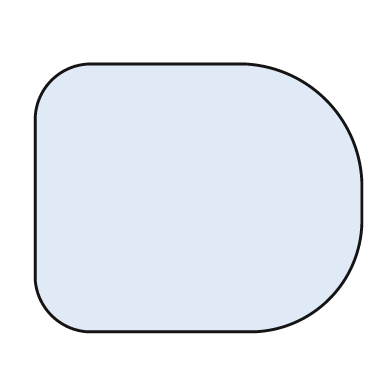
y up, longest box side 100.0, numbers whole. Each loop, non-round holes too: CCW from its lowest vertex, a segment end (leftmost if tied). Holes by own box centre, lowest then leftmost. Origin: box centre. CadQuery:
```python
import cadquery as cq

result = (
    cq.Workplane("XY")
    .moveTo(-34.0, -41.0)
    .lineTo(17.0, -41.0)
    .threePointArc((40.0, -31.0), (50.0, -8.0))
    .lineTo(50.0, 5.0)
    .threePointArc((39.0, 30.0), (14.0, 41.0))
    .lineTo(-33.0, 41.0)
    .threePointArc((-45.0, 36.0), (-50.0, 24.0))
    .lineTo(-50.0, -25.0)
    .threePointArc((-45.0, -36.0), (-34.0, -41.0))
    .close()
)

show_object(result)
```